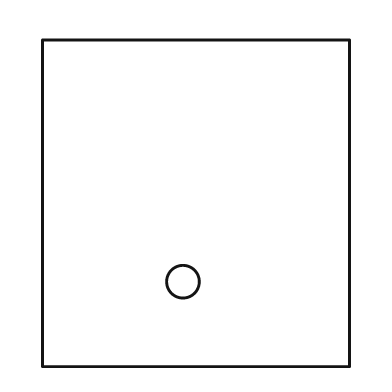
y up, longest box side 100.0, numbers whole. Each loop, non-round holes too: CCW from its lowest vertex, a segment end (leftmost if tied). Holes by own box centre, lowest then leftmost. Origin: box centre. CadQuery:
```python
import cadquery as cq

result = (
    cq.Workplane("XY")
    .moveTo(-47.0, -50.0)
    .lineTo(47.0, -50.0)
    .lineTo(47.0, 50.0)
    .lineTo(-47.0, 50.0)
    .close()
    .moveTo(-4.0, -24.0)
    .circle(5.0)
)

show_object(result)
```